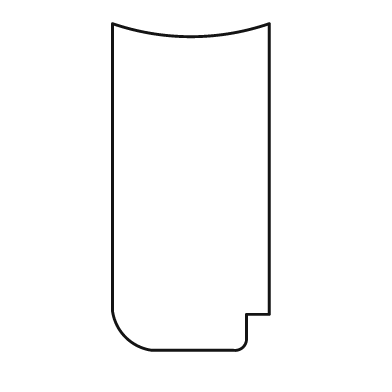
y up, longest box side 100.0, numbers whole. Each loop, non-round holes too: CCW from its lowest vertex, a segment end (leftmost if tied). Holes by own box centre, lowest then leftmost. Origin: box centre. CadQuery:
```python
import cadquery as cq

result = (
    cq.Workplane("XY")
    .moveTo(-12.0, -50.0)
    .lineTo(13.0, -50.0)
    .threePointArc((16.0, -49.0), (17.0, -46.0))
    .lineTo(17.0, -39.0)
    .lineTo(24.0, -39.0)
    .lineTo(24.0, 50.0)
    .threePointArc((0.0, 46.0), (-24.0, 50.0))
    .lineTo(-24.0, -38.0)
    .threePointArc((-20.0, -46.0), (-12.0, -50.0))
    .close()
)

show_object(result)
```